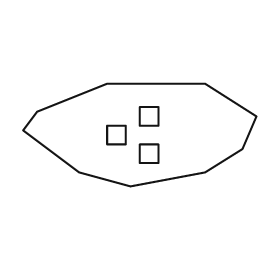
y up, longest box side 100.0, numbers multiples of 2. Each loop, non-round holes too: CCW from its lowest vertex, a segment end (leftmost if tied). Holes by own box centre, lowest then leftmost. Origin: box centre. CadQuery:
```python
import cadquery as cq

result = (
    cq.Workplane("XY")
    .moveTo(-4.0, -22.0)
    .lineTo(28.0, -16.0)
    .lineTo(44.0, -6.0)
    .lineTo(50.0, 8.0)
    .lineTo(28.0, 22.0)
    .lineTo(-14.0, 22.0)
    .lineTo(-44.0, 10.0)
    .lineTo(-50.0, 2.0)
    .lineTo(-26.0, -16.0)
    .close()
    .moveTo(0.0, -12.0)
    .lineTo(8.0, -12.0)
    .lineTo(8.0, -4.0)
    .lineTo(0.0, -4.0)
    .close()
    .moveTo(-14.0, -4.0)
    .lineTo(-6.0, -4.0)
    .lineTo(-6.0, 4.0)
    .lineTo(-14.0, 4.0)
    .close()
    .moveTo(0.0, 4.0)
    .lineTo(8.0, 4.0)
    .lineTo(8.0, 12.0)
    .lineTo(0.0, 12.0)
    .close()
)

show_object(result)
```